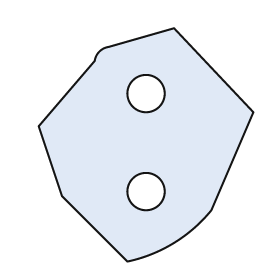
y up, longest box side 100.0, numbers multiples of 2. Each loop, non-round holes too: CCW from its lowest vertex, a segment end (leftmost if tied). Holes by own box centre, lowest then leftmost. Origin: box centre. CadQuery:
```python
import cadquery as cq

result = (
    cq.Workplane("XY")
    .moveTo(-8.0, -50.0)
    .threePointArc((12.0, -42.0), (28.0, -28.0))
    .lineTo(46.0, 14.0)
    .lineTo(12.0, 50.0)
    .lineTo(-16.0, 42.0)
    .threePointArc((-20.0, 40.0), (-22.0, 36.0))
    .lineTo(-46.0, 8.0)
    .lineTo(-36.0, -22.0)
    .close()
    .moveTo(0.0, -20.0)
    .circle(8.0)
    .moveTo(0.0, 22.0)
    .circle(8.0)
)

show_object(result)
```